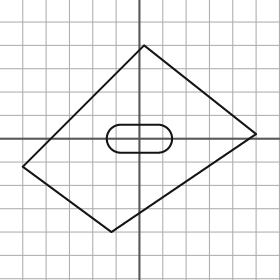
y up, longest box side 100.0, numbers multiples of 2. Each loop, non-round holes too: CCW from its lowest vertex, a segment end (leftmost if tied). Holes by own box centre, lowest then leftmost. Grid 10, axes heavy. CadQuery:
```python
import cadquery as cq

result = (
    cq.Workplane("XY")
    .moveTo(-12.0, -40.0)
    .lineTo(50.0, 2.0)
    .lineTo(2.0, 40.0)
    .lineTo(-50.0, -12.0)
    .close()
    .moveTo(-8.0, -6.0)
    .lineTo(8.0, -6.0)
    .threePointArc((14.0, 0.0), (8.0, 6.0))
    .lineTo(-8.0, 6.0)
    .threePointArc((-14.0, 0.0), (-8.0, -6.0))
    .close()
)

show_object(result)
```